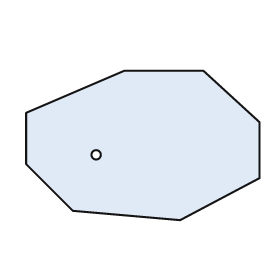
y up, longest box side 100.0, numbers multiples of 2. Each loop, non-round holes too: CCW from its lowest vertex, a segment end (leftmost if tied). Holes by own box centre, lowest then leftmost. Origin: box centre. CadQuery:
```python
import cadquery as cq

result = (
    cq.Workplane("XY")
    .moveTo(16.0, -32.0)
    .lineTo(50.0, -14.0)
    .lineTo(50.0, 10.0)
    .lineTo(26.0, 32.0)
    .lineTo(-8.0, 32.0)
    .lineTo(-50.0, 14.0)
    .lineTo(-50.0, -8.0)
    .lineTo(-30.0, -28.0)
    .close()
    .moveTo(-20.0, -4.0)
    .circle(2.0)
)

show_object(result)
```